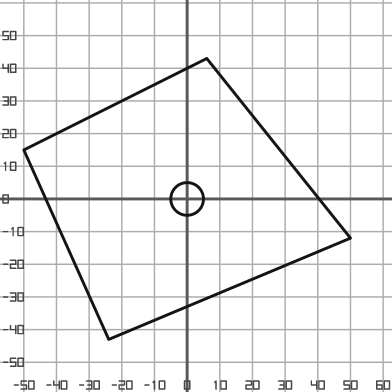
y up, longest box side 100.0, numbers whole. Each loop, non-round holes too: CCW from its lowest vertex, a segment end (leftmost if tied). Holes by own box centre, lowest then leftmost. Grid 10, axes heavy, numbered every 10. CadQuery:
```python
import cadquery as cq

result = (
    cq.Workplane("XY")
    .moveTo(-24.0, -43.0)
    .lineTo(50.0, -12.0)
    .lineTo(6.0, 43.0)
    .lineTo(-50.0, 15.0)
    .close()
    .moveTo(0.0, 0.0)
    .circle(5.0)
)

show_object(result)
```